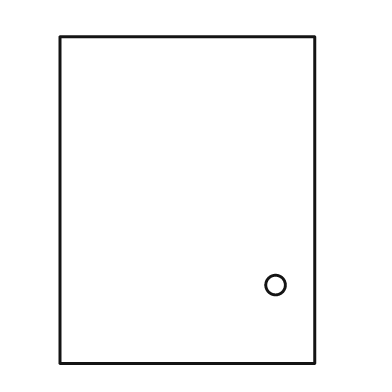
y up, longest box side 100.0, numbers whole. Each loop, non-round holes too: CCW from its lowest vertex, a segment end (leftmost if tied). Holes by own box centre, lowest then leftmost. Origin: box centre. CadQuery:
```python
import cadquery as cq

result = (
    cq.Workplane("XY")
    .moveTo(-39.0, -50.0)
    .lineTo(39.0, -50.0)
    .lineTo(39.0, 50.0)
    .lineTo(-39.0, 50.0)
    .close()
    .moveTo(27.0, -26.0)
    .circle(3.0)
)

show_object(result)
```